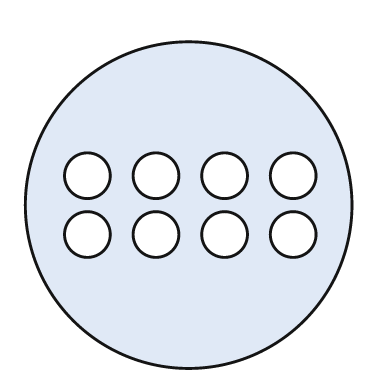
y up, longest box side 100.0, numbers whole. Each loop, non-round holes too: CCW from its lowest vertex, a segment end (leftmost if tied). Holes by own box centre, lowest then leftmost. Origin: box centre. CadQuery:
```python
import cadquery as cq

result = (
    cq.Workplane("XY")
    .moveTo(0.0, 0.0)
    .circle(50.0)
    .moveTo(-31.0, -9.0)
    .circle(7.0)
    .moveTo(-10.0, -9.0)
    .circle(7.0)
    .moveTo(11.0, -9.0)
    .circle(7.0)
    .moveTo(32.0, -9.0)
    .circle(7.0)
    .moveTo(-31.0, 9.0)
    .circle(7.0)
    .moveTo(-10.0, 9.0)
    .circle(7.0)
    .moveTo(11.0, 9.0)
    .circle(7.0)
    .moveTo(32.0, 9.0)
    .circle(7.0)
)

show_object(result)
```